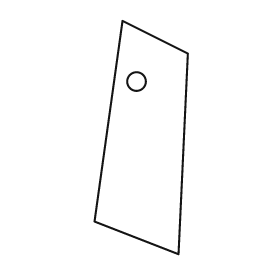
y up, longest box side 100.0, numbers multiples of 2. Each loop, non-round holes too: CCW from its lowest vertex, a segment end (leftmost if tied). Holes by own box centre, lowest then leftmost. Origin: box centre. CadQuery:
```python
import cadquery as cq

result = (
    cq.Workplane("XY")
    .moveTo(16.0, -50.0)
    .lineTo(20.0, 36.0)
    .lineTo(-8.0, 50.0)
    .lineTo(-20.0, -36.0)
    .close()
    .moveTo(-2.0, 24.0)
    .circle(4.0)
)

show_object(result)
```